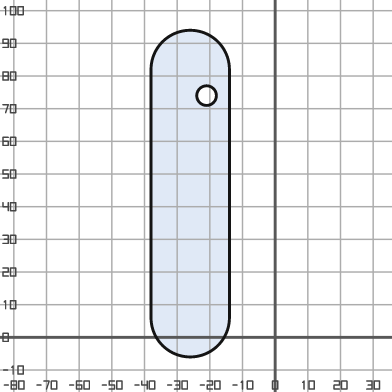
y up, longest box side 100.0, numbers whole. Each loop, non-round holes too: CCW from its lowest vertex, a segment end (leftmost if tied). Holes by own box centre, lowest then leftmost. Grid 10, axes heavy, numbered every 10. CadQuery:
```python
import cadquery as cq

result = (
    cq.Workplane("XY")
    .moveTo(-38.0, 6.0)
    .threePointArc((-26.0, -6.0), (-14.0, 6.0))
    .lineTo(-14.0, 82.0)
    .threePointArc((-26.0, 94.0), (-38.0, 82.0))
    .close()
    .moveTo(-21.0, 74.0)
    .circle(3.0)
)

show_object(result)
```